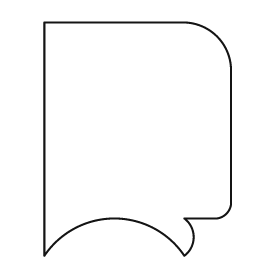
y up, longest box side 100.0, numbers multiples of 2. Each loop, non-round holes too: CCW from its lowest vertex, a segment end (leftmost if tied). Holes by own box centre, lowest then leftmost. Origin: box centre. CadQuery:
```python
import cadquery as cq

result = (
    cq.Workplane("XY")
    .moveTo(-40.0, -50.0)
    .threePointArc((-10.0, -34.0), (20.0, -50.0))
    .threePointArc((24.0, -42.0), (20.0, -34.0))
    .lineTo(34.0, -34.0)
    .threePointArc((38.0, -32.0), (40.0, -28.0))
    .lineTo(40.0, 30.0)
    .threePointArc((34.0, 44.0), (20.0, 50.0))
    .lineTo(-40.0, 50.0)
    .close()
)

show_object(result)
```